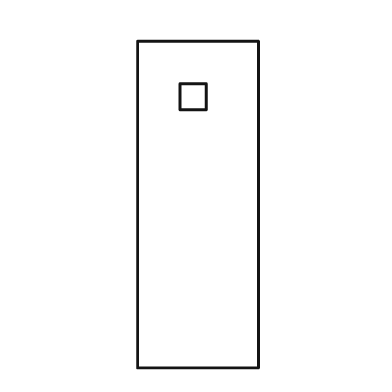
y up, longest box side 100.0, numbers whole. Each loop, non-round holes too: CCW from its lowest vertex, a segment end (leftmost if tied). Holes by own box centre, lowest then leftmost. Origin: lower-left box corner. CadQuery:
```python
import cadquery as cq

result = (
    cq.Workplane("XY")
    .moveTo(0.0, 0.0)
    .lineTo(37.0, 0.0)
    .lineTo(37.0, 100.0)
    .lineTo(0.0, 100.0)
    .close()
    .moveTo(13.0, 79.0)
    .lineTo(21.0, 79.0)
    .lineTo(21.0, 87.0)
    .lineTo(13.0, 87.0)
    .close()
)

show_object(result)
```